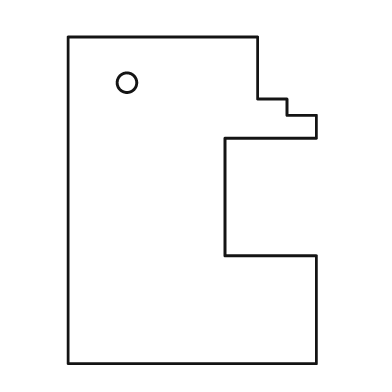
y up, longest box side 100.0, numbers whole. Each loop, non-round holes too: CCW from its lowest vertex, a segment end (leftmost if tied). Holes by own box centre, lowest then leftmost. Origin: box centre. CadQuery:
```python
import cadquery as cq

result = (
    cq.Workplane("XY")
    .moveTo(-38.0, -50.0)
    .lineTo(38.0, -50.0)
    .lineTo(38.0, -17.0)
    .lineTo(10.0, -17.0)
    .lineTo(10.0, 19.0)
    .lineTo(38.0, 19.0)
    .lineTo(38.0, 26.0)
    .lineTo(29.0, 26.0)
    .lineTo(29.0, 31.0)
    .lineTo(20.0, 31.0)
    .lineTo(20.0, 50.0)
    .lineTo(-38.0, 50.0)
    .close()
    .moveTo(-20.0, 36.0)
    .circle(3.0)
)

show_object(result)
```